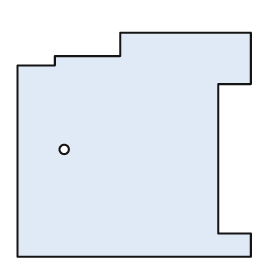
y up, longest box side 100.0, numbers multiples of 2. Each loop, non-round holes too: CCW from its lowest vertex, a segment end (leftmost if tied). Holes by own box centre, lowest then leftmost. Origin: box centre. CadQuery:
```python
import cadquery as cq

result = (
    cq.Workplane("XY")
    .moveTo(-50.0, -48.0)
    .lineTo(50.0, -48.0)
    .lineTo(50.0, -38.0)
    .lineTo(36.0, -38.0)
    .lineTo(36.0, 26.0)
    .lineTo(50.0, 26.0)
    .lineTo(50.0, 48.0)
    .lineTo(-6.0, 48.0)
    .lineTo(-6.0, 38.0)
    .lineTo(-34.0, 38.0)
    .lineTo(-34.0, 34.0)
    .lineTo(-50.0, 34.0)
    .close()
    .moveTo(-30.0, -2.0)
    .circle(2.0)
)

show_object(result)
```